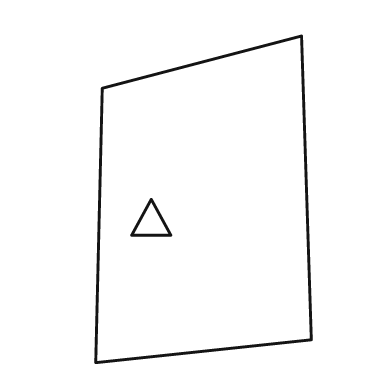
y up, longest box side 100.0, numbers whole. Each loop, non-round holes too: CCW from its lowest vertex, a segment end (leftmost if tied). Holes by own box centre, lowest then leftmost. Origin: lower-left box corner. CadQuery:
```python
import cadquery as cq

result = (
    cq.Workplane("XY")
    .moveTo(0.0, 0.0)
    .lineTo(66.0, 7.0)
    .lineTo(63.0, 100.0)
    .lineTo(2.0, 84.0)
    .close()
    .moveTo(11.0, 39.0)
    .lineTo(23.0, 39.0)
    .lineTo(17.0, 50.0)
    .close()
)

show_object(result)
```